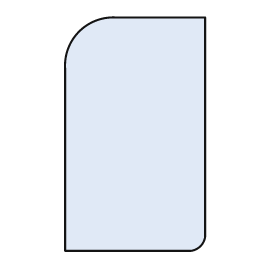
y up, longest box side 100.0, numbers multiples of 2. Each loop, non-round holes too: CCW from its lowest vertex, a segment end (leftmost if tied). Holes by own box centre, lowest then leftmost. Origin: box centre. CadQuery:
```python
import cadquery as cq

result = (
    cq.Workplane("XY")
    .moveTo(-30.0, -50.0)
    .lineTo(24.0, -50.0)
    .threePointArc((28.0, -48.0), (30.0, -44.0))
    .lineTo(30.0, 50.0)
    .lineTo(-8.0, 50.0)
    .threePointArc((-24.0, 44.0), (-30.0, 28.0))
    .close()
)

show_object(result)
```